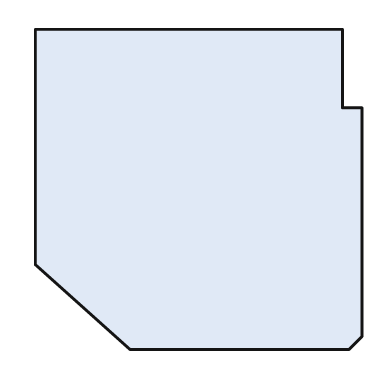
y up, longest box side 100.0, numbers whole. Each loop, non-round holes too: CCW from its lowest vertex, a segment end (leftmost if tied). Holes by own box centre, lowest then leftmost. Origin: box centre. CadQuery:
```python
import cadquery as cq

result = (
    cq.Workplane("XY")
    .moveTo(-21.0, -49.0)
    .lineTo(46.0, -49.0)
    .lineTo(50.0, -45.0)
    .lineTo(50.0, 25.0)
    .lineTo(44.0, 25.0)
    .lineTo(44.0, 49.0)
    .lineTo(-50.0, 49.0)
    .lineTo(-50.0, -23.0)
    .close()
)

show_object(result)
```